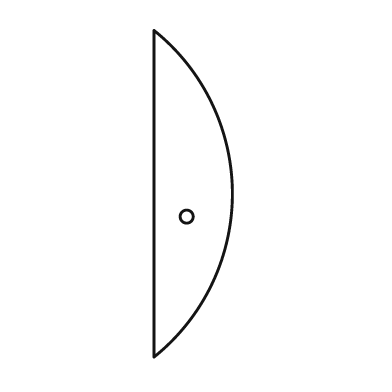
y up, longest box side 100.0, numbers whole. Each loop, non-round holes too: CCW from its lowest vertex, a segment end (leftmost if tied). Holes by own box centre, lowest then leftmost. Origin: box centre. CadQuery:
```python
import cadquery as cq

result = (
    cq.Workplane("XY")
    .moveTo(-12.0, -50.0)
    .threePointArc((12.0, 0.0), (-12.0, 50.0))
    .close()
    .moveTo(-2.0, -7.0)
    .circle(2.0)
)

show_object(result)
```